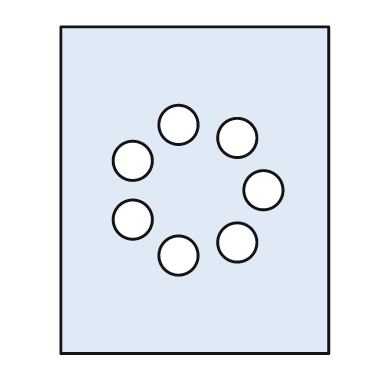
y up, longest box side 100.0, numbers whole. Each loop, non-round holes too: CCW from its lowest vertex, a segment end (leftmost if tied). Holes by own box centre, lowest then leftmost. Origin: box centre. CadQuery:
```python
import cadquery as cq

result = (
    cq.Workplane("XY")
    .moveTo(-41.0, -50.0)
    .lineTo(41.0, -50.0)
    .lineTo(41.0, 50.0)
    .lineTo(-41.0, 50.0)
    .close()
    .moveTo(-5.0, -20.0)
    .circle(6.0)
    .moveTo(13.0, -16.0)
    .circle(6.0)
    .moveTo(-19.0, -9.0)
    .circle(6.0)
    .moveTo(21.0, 0.0)
    .circle(6.0)
    .moveTo(-19.0, 9.0)
    .circle(6.0)
    .moveTo(13.0, 16.0)
    .circle(6.0)
    .moveTo(-5.0, 20.0)
    .circle(6.0)
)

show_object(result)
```